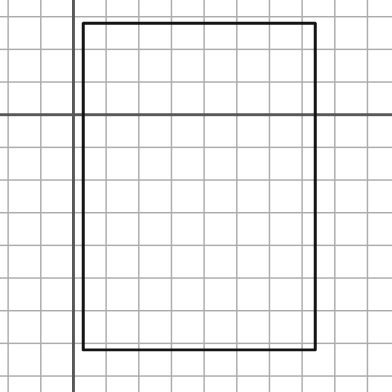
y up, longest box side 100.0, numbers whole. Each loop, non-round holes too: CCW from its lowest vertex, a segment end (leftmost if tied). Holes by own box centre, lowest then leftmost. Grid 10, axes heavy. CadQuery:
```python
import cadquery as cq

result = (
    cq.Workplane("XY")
    .moveTo(3.0, -72.0)
    .lineTo(74.0, -72.0)
    .lineTo(74.0, 28.0)
    .lineTo(3.0, 28.0)
    .close()
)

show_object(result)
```